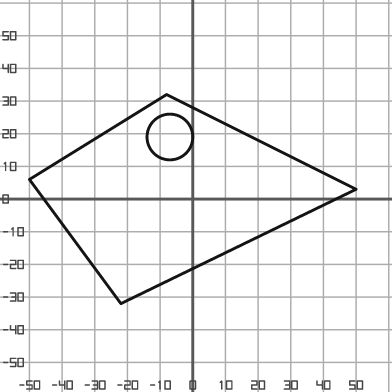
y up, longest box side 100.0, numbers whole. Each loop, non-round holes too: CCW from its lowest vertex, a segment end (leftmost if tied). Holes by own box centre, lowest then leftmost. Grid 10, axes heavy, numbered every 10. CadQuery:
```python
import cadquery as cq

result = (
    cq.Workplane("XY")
    .moveTo(-22.0, -32.0)
    .lineTo(50.0, 3.0)
    .lineTo(-8.0, 32.0)
    .lineTo(-50.0, 6.0)
    .close()
    .moveTo(-7.0, 19.0)
    .circle(7.0)
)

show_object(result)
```